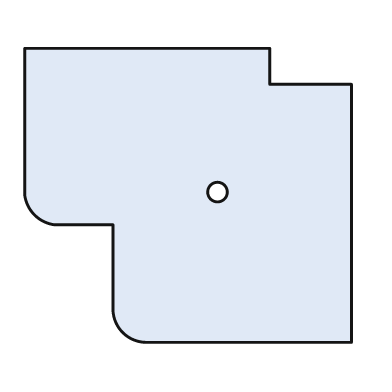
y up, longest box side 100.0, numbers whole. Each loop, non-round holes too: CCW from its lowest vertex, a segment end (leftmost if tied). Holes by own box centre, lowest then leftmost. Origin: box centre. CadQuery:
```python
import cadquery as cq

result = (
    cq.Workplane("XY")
    .moveTo(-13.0, -45.0)
    .lineTo(50.0, -45.0)
    .lineTo(50.0, 34.0)
    .lineTo(25.0, 34.0)
    .lineTo(25.0, 45.0)
    .lineTo(-50.0, 45.0)
    .lineTo(-50.0, 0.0)
    .threePointArc((-47.0, -6.0), (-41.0, -9.0))
    .lineTo(-23.0, -9.0)
    .lineTo(-23.0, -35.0)
    .threePointArc((-20.0, -42.0), (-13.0, -45.0))
    .close()
    .moveTo(9.0, 1.0)
    .circle(3.0)
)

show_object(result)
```